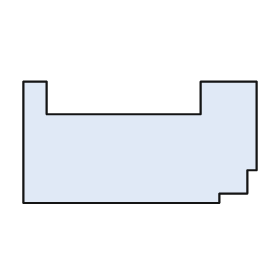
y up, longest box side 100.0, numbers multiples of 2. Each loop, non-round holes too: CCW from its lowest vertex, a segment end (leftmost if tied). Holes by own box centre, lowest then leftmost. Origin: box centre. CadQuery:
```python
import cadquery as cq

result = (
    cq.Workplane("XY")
    .moveTo(-50.0, -26.0)
    .lineTo(34.0, -26.0)
    .lineTo(34.0, -22.0)
    .lineTo(46.0, -22.0)
    .lineTo(46.0, -12.0)
    .lineTo(50.0, -12.0)
    .lineTo(50.0, 26.0)
    .lineTo(26.0, 26.0)
    .lineTo(26.0, 12.0)
    .lineTo(-40.0, 12.0)
    .lineTo(-40.0, 26.0)
    .lineTo(-50.0, 26.0)
    .close()
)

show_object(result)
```